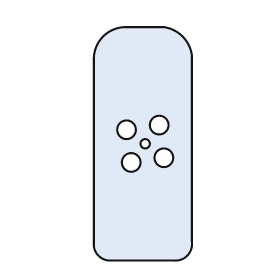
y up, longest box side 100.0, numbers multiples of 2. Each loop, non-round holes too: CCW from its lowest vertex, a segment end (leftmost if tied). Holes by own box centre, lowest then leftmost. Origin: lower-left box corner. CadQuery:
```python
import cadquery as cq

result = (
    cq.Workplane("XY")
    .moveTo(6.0, 0.0)
    .lineTo(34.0, 0.0)
    .threePointArc((40.0, 2.0), (42.0, 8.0))
    .lineTo(42.0, 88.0)
    .threePointArc((38.0, 96.0), (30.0, 100.0))
    .lineTo(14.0, 100.0)
    .threePointArc((4.0, 96.0), (0.0, 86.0))
    .lineTo(0.0, 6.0)
    .threePointArc((2.0, 2.0), (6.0, 0.0))
    .close()
    .moveTo(16.0, 42.0)
    .circle(4.0)
    .moveTo(30.0, 44.0)
    .circle(4.0)
    .moveTo(22.0, 50.0)
    .circle(2.0)
    .moveTo(14.0, 56.0)
    .circle(4.0)
    .moveTo(28.0, 58.0)
    .circle(4.0)
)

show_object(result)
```